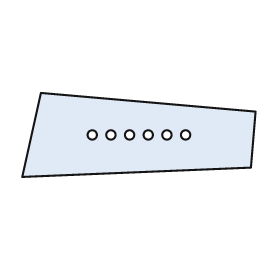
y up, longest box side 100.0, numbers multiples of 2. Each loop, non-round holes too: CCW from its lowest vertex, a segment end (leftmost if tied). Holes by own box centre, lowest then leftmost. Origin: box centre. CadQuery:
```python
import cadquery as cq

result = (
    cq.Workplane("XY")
    .moveTo(-50.0, -18.0)
    .lineTo(48.0, -14.0)
    .lineTo(50.0, 10.0)
    .lineTo(-42.0, 18.0)
    .close()
    .moveTo(-20.0, 0.0)
    .circle(2.0)
    .moveTo(-12.0, 0.0)
    .circle(2.0)
    .moveTo(-4.0, 0.0)
    .circle(2.0)
    .moveTo(4.0, 0.0)
    .circle(2.0)
    .moveTo(12.0, 0.0)
    .circle(2.0)
    .moveTo(20.0, 0.0)
    .circle(2.0)
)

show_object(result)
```